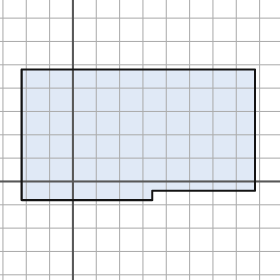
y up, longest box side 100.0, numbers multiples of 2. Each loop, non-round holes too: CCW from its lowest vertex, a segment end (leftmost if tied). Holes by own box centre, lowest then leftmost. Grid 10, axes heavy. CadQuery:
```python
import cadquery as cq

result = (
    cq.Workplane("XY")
    .moveTo(-22.0, -8.0)
    .lineTo(34.0, -8.0)
    .lineTo(34.0, -4.0)
    .lineTo(78.0, -4.0)
    .lineTo(78.0, 48.0)
    .lineTo(-22.0, 48.0)
    .close()
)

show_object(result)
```